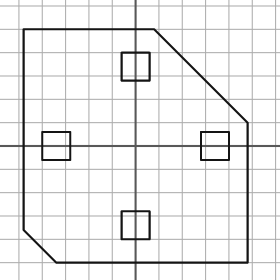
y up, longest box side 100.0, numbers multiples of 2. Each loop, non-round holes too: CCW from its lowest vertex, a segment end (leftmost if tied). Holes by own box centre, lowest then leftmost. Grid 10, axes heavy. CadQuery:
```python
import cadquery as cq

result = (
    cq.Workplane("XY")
    .moveTo(-34.0, -50.0)
    .lineTo(48.0, -50.0)
    .lineTo(48.0, 10.0)
    .lineTo(8.0, 50.0)
    .lineTo(-48.0, 50.0)
    .lineTo(-48.0, -36.0)
    .close()
    .moveTo(-6.0, -40.0)
    .lineTo(6.0, -40.0)
    .lineTo(6.0, -28.0)
    .lineTo(-6.0, -28.0)
    .close()
    .moveTo(-40.0, -6.0)
    .lineTo(-28.0, -6.0)
    .lineTo(-28.0, 6.0)
    .lineTo(-40.0, 6.0)
    .close()
    .moveTo(28.0, -6.0)
    .lineTo(40.0, -6.0)
    .lineTo(40.0, 6.0)
    .lineTo(28.0, 6.0)
    .close()
    .moveTo(-6.0, 28.0)
    .lineTo(6.0, 28.0)
    .lineTo(6.0, 40.0)
    .lineTo(-6.0, 40.0)
    .close()
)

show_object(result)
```